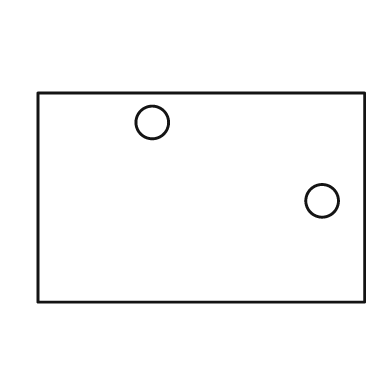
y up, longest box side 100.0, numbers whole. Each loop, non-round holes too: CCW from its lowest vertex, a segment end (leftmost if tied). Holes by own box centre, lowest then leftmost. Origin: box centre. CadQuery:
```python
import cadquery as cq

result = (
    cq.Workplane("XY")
    .moveTo(-50.0, -32.0)
    .lineTo(50.0, -32.0)
    .lineTo(50.0, 32.0)
    .lineTo(-50.0, 32.0)
    .close()
    .moveTo(37.0, -1.0)
    .circle(5.0)
    .moveTo(-15.0, 23.0)
    .circle(5.0)
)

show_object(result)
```